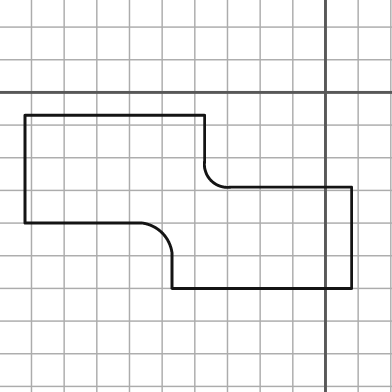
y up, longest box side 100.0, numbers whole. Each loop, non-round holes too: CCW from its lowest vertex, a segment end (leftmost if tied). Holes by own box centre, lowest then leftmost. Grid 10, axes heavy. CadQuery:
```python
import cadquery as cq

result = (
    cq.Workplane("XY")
    .moveTo(-47.0, -60.0)
    .lineTo(8.0, -60.0)
    .lineTo(8.0, -29.0)
    .lineTo(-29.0, -29.0)
    .threePointArc((-35.0, -27.0), (-37.0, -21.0))
    .lineTo(-37.0, -7.0)
    .lineTo(-92.0, -7.0)
    .lineTo(-92.0, -40.0)
    .lineTo(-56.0, -40.0)
    .threePointArc((-50.0, -43.0), (-47.0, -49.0))
    .close()
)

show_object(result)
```